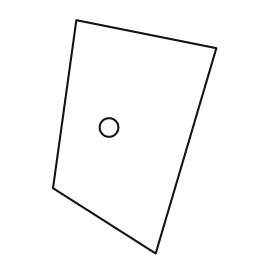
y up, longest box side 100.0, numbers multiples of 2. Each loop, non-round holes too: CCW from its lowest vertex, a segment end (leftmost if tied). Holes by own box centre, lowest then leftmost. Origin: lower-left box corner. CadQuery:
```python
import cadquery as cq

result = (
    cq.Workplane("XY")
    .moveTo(44.0, 0.0)
    .lineTo(70.0, 88.0)
    .lineTo(10.0, 100.0)
    .lineTo(0.0, 28.0)
    .close()
    .moveTo(24.0, 54.0)
    .circle(4.0)
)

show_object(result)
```